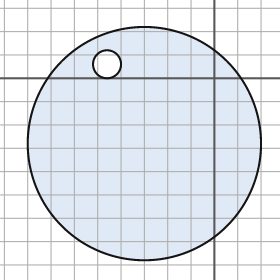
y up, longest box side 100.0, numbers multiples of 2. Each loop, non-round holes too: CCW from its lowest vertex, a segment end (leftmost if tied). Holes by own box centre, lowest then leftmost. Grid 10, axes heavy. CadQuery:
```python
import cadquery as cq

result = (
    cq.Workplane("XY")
    .moveTo(-30.0, -28.0)
    .circle(50.0)
    .moveTo(-46.0, 6.0)
    .circle(6.0)
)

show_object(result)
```